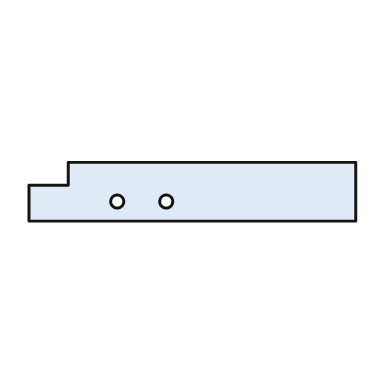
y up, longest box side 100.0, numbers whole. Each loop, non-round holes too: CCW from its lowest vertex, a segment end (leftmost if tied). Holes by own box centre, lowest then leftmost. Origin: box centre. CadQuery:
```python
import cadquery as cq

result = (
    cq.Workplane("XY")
    .moveTo(-50.0, -9.0)
    .lineTo(50.0, -9.0)
    .lineTo(50.0, 9.0)
    .lineTo(-38.0, 9.0)
    .lineTo(-38.0, 2.0)
    .lineTo(-50.0, 2.0)
    .close()
    .moveTo(-23.0, -3.0)
    .circle(2.0)
    .moveTo(-8.0, -3.0)
    .circle(2.0)
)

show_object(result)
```